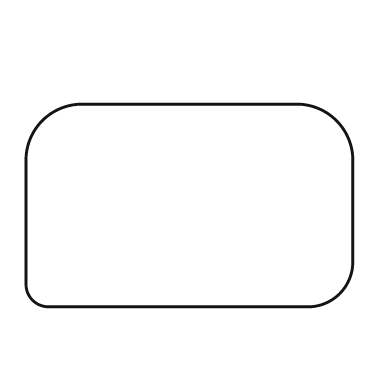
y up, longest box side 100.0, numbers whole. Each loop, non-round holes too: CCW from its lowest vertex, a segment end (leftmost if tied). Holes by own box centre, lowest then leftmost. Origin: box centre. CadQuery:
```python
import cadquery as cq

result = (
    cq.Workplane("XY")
    .moveTo(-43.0, -31.0)
    .lineTo(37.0, -31.0)
    .threePointArc((46.0, -27.0), (50.0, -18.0))
    .lineTo(50.0, 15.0)
    .threePointArc((45.0, 26.0), (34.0, 31.0))
    .lineTo(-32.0, 31.0)
    .threePointArc((-45.0, 26.0), (-50.0, 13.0))
    .lineTo(-50.0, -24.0)
    .threePointArc((-48.0, -29.0), (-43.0, -31.0))
    .close()
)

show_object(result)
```